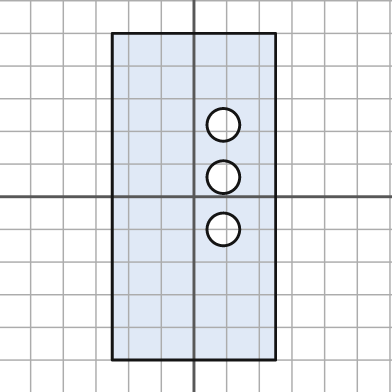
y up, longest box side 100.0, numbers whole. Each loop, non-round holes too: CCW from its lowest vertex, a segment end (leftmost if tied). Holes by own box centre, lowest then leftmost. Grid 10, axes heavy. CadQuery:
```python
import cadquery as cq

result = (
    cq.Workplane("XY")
    .moveTo(-25.0, -50.0)
    .lineTo(25.0, -50.0)
    .lineTo(25.0, 50.0)
    .lineTo(-25.0, 50.0)
    .close()
    .moveTo(9.0, -10.0)
    .circle(5.0)
    .moveTo(9.0, 6.0)
    .circle(5.0)
    .moveTo(9.0, 22.0)
    .circle(5.0)
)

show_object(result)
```